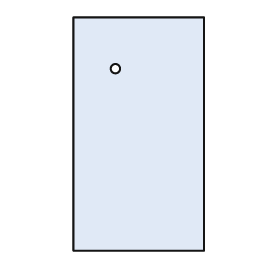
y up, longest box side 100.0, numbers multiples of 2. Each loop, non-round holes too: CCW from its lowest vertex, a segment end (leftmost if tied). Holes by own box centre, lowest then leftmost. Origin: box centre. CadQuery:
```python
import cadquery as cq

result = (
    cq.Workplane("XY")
    .moveTo(-28.0, -50.0)
    .lineTo(28.0, -50.0)
    .lineTo(28.0, 50.0)
    .lineTo(-28.0, 50.0)
    .close()
    .moveTo(-10.0, 28.0)
    .circle(2.0)
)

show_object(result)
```